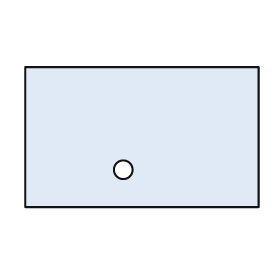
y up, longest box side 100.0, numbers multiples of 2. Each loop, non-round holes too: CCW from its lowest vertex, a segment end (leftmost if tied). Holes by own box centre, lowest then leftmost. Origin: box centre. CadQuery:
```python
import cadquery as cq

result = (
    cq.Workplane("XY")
    .moveTo(-50.0, -30.0)
    .lineTo(50.0, -30.0)
    .lineTo(50.0, 30.0)
    .lineTo(-50.0, 30.0)
    .close()
    .moveTo(-8.0, -14.0)
    .circle(4.0)
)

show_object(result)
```